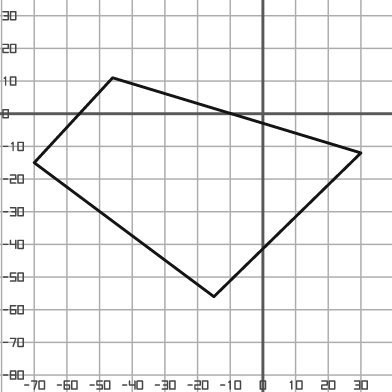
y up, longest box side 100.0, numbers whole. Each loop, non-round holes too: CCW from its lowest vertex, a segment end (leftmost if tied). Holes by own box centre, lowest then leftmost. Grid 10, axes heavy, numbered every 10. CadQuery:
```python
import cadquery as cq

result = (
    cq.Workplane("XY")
    .moveTo(-15.0, -56.0)
    .lineTo(30.0, -12.0)
    .lineTo(-46.0, 11.0)
    .lineTo(-70.0, -15.0)
    .close()
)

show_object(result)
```